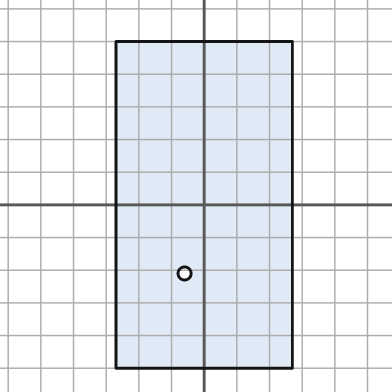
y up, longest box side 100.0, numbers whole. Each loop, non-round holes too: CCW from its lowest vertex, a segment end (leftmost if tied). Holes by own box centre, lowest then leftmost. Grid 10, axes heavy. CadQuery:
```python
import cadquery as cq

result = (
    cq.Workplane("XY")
    .moveTo(-27.0, -50.0)
    .lineTo(27.0, -50.0)
    .lineTo(27.0, 50.0)
    .lineTo(-27.0, 50.0)
    .close()
    .moveTo(-6.0, -21.0)
    .circle(2.0)
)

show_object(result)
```